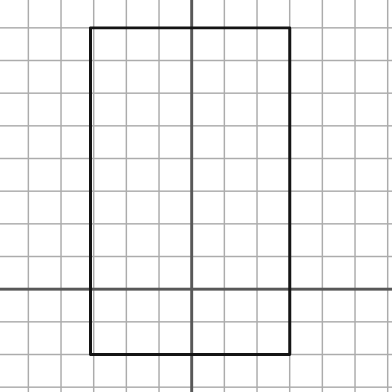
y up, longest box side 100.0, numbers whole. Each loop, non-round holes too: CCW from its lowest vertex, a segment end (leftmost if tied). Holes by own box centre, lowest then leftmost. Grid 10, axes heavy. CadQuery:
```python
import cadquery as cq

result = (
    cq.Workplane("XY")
    .moveTo(-31.0, -20.0)
    .lineTo(30.0, -20.0)
    .lineTo(30.0, 80.0)
    .lineTo(-31.0, 80.0)
    .close()
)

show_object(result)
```